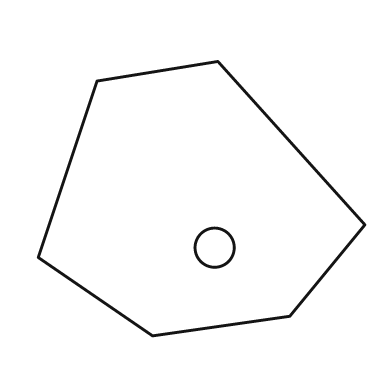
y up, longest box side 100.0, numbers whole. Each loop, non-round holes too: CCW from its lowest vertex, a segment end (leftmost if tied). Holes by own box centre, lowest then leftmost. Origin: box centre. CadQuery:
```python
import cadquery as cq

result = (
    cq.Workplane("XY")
    .moveTo(-15.0, -42.0)
    .lineTo(27.0, -36.0)
    .lineTo(50.0, -8.0)
    .lineTo(5.0, 42.0)
    .lineTo(-32.0, 36.0)
    .lineTo(-50.0, -18.0)
    .close()
    .moveTo(4.0, -15.0)
    .circle(6.0)
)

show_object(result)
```